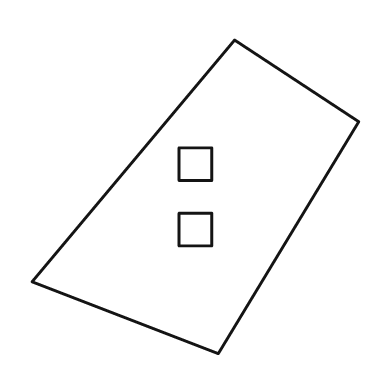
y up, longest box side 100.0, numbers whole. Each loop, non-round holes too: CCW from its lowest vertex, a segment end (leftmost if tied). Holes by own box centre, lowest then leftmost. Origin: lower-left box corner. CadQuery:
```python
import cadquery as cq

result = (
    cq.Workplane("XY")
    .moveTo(57.0, 0.0)
    .lineTo(100.0, 71.0)
    .lineTo(62.0, 96.0)
    .lineTo(0.0, 22.0)
    .close()
    .moveTo(45.0, 33.0)
    .lineTo(55.0, 33.0)
    .lineTo(55.0, 43.0)
    .lineTo(45.0, 43.0)
    .close()
    .moveTo(45.0, 53.0)
    .lineTo(55.0, 53.0)
    .lineTo(55.0, 63.0)
    .lineTo(45.0, 63.0)
    .close()
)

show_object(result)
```